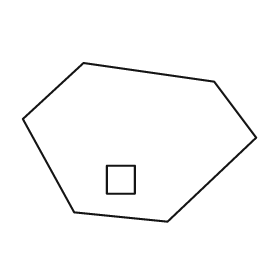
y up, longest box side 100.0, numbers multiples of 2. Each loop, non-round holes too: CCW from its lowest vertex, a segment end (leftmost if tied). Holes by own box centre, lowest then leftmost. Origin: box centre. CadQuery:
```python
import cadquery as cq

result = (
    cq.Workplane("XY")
    .moveTo(12.0, -34.0)
    .lineTo(50.0, 2.0)
    .lineTo(32.0, 26.0)
    .lineTo(-24.0, 34.0)
    .lineTo(-50.0, 10.0)
    .lineTo(-28.0, -30.0)
    .close()
    .moveTo(-14.0, -22.0)
    .lineTo(-2.0, -22.0)
    .lineTo(-2.0, -10.0)
    .lineTo(-14.0, -10.0)
    .close()
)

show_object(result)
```